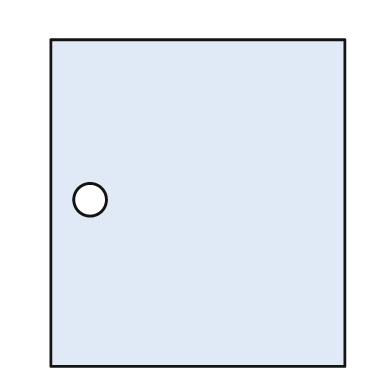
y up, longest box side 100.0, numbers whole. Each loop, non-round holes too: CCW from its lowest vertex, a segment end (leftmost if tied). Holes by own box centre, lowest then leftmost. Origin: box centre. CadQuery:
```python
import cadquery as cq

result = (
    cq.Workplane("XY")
    .moveTo(-45.0, -50.0)
    .lineTo(45.0, -50.0)
    .lineTo(45.0, 50.0)
    .lineTo(-45.0, 50.0)
    .close()
    .moveTo(-33.0, 1.0)
    .circle(5.0)
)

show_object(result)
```